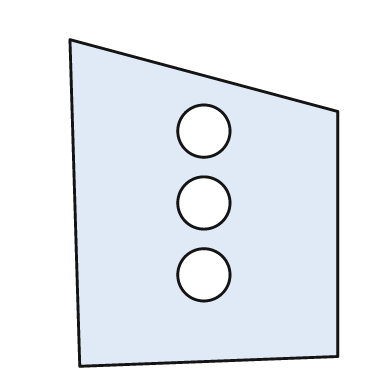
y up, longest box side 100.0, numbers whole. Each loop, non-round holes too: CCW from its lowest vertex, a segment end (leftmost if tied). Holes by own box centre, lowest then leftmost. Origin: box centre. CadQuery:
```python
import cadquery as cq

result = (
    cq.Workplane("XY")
    .moveTo(-38.0, -50.0)
    .lineTo(41.0, -47.0)
    .lineTo(41.0, 28.0)
    .lineTo(-41.0, 50.0)
    .close()
    .moveTo(0.0, -22.0)
    .circle(8.0)
    .moveTo(0.0, 0.0)
    .circle(8.0)
    .moveTo(0.0, 22.0)
    .circle(8.0)
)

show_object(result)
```